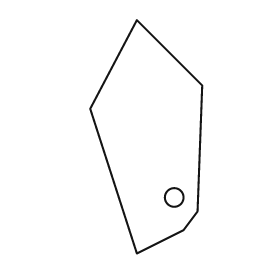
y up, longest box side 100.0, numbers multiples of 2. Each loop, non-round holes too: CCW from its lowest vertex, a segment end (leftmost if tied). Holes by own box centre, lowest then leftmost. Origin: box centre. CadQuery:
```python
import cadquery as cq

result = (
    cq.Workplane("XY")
    .moveTo(-4.0, -50.0)
    .lineTo(16.0, -40.0)
    .lineTo(22.0, -32.0)
    .lineTo(24.0, 22.0)
    .lineTo(-4.0, 50.0)
    .lineTo(-24.0, 12.0)
    .close()
    .moveTo(12.0, -26.0)
    .circle(4.0)
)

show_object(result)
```